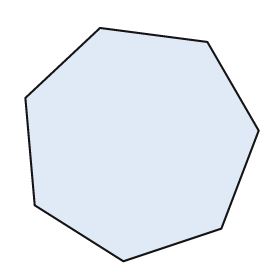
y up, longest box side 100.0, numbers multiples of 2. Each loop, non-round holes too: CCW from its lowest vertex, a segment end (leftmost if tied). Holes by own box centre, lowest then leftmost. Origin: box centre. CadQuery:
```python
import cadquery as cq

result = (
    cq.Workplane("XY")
    .moveTo(-8.0, -50.0)
    .lineTo(34.0, -36.0)
    .lineTo(50.0, 6.0)
    .lineTo(28.0, 44.0)
    .lineTo(-18.0, 50.0)
    .lineTo(-50.0, 20.0)
    .lineTo(-46.0, -26.0)
    .close()
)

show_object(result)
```